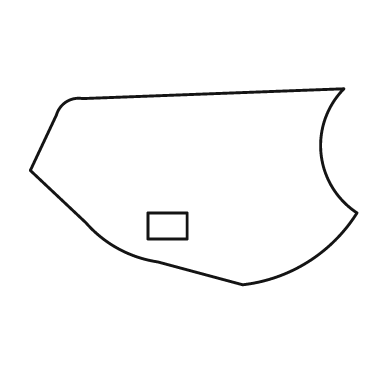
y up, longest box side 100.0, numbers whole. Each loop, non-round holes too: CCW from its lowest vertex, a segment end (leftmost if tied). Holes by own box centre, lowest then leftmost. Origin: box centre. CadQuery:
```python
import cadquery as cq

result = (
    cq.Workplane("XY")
    .moveTo(15.0, -30.0)
    .threePointArc((35.0, -23.0), (50.0, -8.0))
    .threePointArc((39.0, 10.0), (46.0, 30.0))
    .lineTo(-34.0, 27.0)
    .threePointArc((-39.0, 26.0), (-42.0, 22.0))
    .lineTo(-50.0, 5.0)
    .lineTo(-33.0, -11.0)
    .threePointArc((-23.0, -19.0), (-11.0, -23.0))
    .close()
    .moveTo(-14.0, -16.0)
    .lineTo(-2.0, -16.0)
    .lineTo(-2.0, -8.0)
    .lineTo(-14.0, -8.0)
    .close()
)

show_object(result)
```